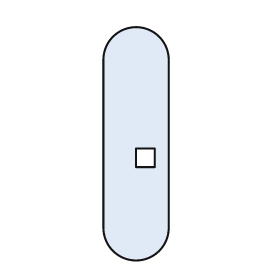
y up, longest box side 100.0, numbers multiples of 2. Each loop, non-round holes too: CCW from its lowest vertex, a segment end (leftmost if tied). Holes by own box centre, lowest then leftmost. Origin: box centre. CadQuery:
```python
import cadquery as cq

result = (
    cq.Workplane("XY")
    .moveTo(-14.0, -36.0)
    .threePointArc((0.0, -50.0), (14.0, -36.0))
    .lineTo(14.0, 36.0)
    .threePointArc((0.0, 50.0), (-14.0, 36.0))
    .close()
    .moveTo(0.0, -10.0)
    .lineTo(8.0, -10.0)
    .lineTo(8.0, -2.0)
    .lineTo(0.0, -2.0)
    .close()
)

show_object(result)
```